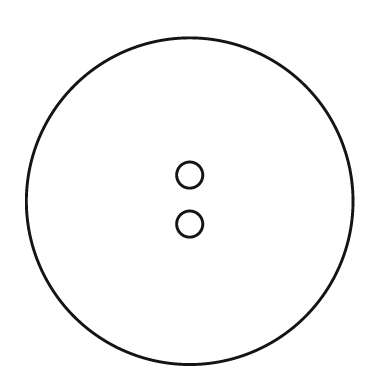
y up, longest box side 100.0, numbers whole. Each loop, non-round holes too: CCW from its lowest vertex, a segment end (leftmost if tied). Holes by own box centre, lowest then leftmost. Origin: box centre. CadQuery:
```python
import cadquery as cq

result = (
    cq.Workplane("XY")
    .moveTo(0.0, 0.0)
    .circle(50.0)
    .moveTo(0.0, -7.0)
    .circle(4.0)
    .moveTo(0.0, 8.0)
    .circle(4.0)
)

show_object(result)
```